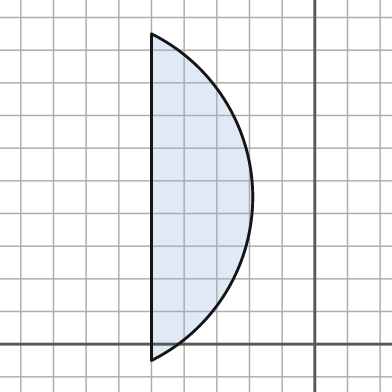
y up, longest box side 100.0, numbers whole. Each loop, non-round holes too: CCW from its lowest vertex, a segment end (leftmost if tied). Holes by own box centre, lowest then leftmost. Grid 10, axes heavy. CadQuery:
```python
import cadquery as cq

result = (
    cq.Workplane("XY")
    .moveTo(-50.0, -5.0)
    .threePointArc((-19.0, 45.0), (-50.0, 95.0))
    .close()
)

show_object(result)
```